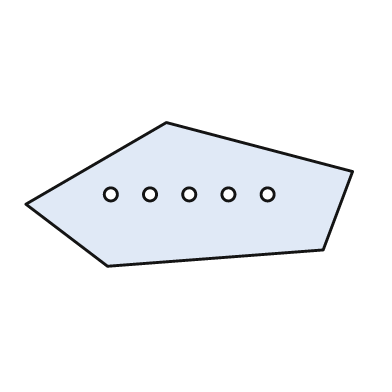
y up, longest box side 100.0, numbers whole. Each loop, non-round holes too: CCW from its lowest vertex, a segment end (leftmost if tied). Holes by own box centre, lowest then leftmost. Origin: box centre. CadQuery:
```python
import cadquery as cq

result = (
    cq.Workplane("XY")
    .moveTo(-25.0, -22.0)
    .lineTo(41.0, -17.0)
    .lineTo(50.0, 7.0)
    .lineTo(-7.0, 22.0)
    .lineTo(-50.0, -3.0)
    .close()
    .moveTo(-24.0, 0.0)
    .circle(2.0)
    .moveTo(-12.0, 0.0)
    .circle(2.0)
    .moveTo(0.0, 0.0)
    .circle(2.0)
    .moveTo(12.0, 0.0)
    .circle(2.0)
    .moveTo(24.0, 0.0)
    .circle(2.0)
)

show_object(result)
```